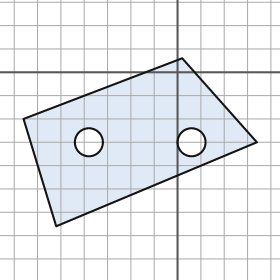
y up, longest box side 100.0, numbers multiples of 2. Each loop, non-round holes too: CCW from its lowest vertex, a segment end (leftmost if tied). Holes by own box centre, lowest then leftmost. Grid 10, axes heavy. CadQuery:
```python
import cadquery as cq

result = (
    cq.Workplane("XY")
    .moveTo(-52.0, -66.0)
    .lineTo(34.0, -30.0)
    .lineTo(2.0, 6.0)
    .lineTo(-66.0, -20.0)
    .close()
    .moveTo(-38.0, -30.0)
    .circle(6.0)
    .moveTo(6.0, -30.0)
    .circle(6.0)
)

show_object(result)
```